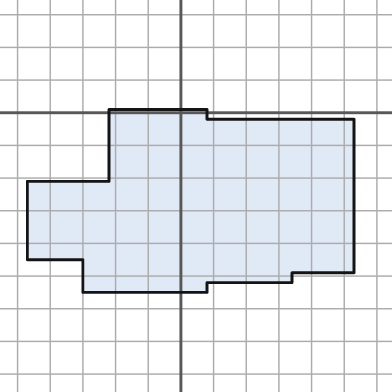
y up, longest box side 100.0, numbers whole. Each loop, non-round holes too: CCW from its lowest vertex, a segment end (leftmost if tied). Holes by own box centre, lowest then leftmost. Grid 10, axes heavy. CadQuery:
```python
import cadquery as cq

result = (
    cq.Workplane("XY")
    .moveTo(-30.0, -55.0)
    .lineTo(8.0, -55.0)
    .lineTo(8.0, -52.0)
    .lineTo(34.0, -52.0)
    .lineTo(34.0, -49.0)
    .lineTo(53.0, -49.0)
    .lineTo(53.0, -2.0)
    .lineTo(8.0, -2.0)
    .lineTo(8.0, 1.0)
    .lineTo(-22.0, 1.0)
    .lineTo(-22.0, -21.0)
    .lineTo(-47.0, -21.0)
    .lineTo(-47.0, -45.0)
    .lineTo(-30.0, -45.0)
    .close()
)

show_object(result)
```